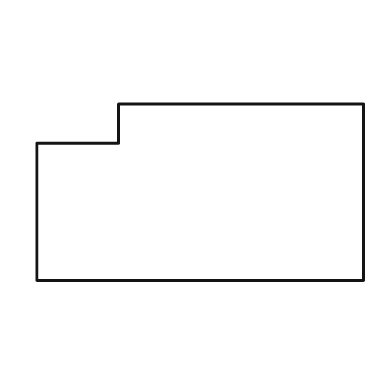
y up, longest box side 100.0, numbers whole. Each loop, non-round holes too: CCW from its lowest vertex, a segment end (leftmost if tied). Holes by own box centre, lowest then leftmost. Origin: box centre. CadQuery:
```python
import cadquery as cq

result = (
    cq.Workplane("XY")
    .moveTo(-50.0, -27.0)
    .lineTo(50.0, -27.0)
    .lineTo(50.0, 27.0)
    .lineTo(-25.0, 27.0)
    .lineTo(-25.0, 15.0)
    .lineTo(-50.0, 15.0)
    .close()
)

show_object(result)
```